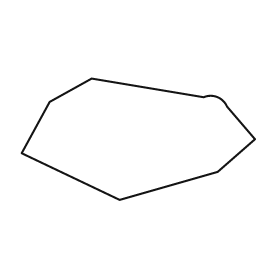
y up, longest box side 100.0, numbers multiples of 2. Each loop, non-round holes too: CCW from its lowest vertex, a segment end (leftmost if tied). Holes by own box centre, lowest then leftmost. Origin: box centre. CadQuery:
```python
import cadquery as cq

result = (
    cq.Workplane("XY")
    .moveTo(-8.0, -26.0)
    .lineTo(34.0, -14.0)
    .lineTo(50.0, 0.0)
    .lineTo(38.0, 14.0)
    .threePointArc((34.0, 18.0), (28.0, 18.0))
    .lineTo(-20.0, 26.0)
    .lineTo(-38.0, 16.0)
    .lineTo(-50.0, -6.0)
    .close()
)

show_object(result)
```